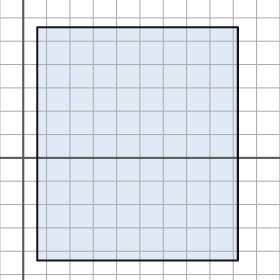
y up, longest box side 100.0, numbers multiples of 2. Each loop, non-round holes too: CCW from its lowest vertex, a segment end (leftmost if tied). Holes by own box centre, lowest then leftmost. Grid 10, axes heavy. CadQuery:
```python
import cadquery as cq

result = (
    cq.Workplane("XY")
    .moveTo(6.0, -44.0)
    .lineTo(92.0, -44.0)
    .lineTo(92.0, 56.0)
    .lineTo(6.0, 56.0)
    .close()
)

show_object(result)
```